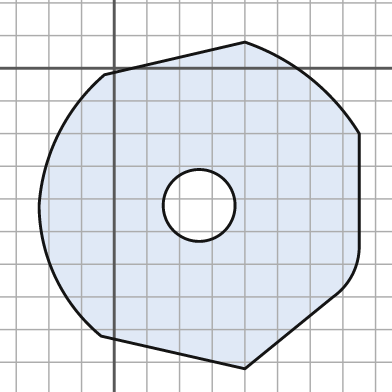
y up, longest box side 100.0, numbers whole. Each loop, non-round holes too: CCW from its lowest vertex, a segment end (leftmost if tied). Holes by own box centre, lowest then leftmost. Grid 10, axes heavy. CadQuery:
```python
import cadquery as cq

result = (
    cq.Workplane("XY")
    .moveTo(40.0, -92.0)
    .lineTo(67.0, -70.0)
    .threePointArc((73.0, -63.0), (75.0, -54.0))
    .lineTo(75.0, -20.0)
    .threePointArc((60.0, -3.0), (40.0, 8.0))
    .lineTo(-3.0, -2.0)
    .threePointArc((-17.0, -20.0), (-23.0, -42.0))
    .threePointArc((-18.0, -64.0), (-4.0, -82.0))
    .close()
    .moveTo(26.0, -42.0)
    .circle(11.0)
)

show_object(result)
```